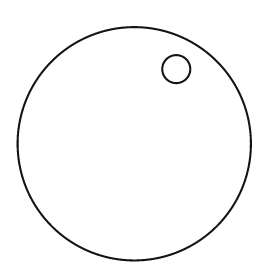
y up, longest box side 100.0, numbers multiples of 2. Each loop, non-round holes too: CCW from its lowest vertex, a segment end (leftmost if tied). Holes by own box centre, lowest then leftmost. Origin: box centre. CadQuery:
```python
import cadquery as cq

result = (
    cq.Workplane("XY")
    .moveTo(0.0, 0.0)
    .circle(50.0)
    .moveTo(18.0, 32.0)
    .circle(6.0)
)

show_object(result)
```